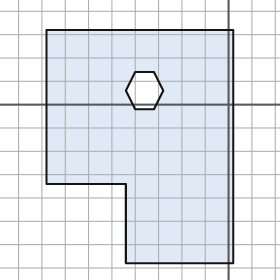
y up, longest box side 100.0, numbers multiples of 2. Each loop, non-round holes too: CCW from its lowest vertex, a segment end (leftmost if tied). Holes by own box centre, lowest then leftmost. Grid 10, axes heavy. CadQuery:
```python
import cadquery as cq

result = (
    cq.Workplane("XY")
    .moveTo(-44.0, -68.0)
    .lineTo(2.0, -68.0)
    .lineTo(2.0, 32.0)
    .lineTo(-78.0, 32.0)
    .lineTo(-78.0, -34.0)
    .lineTo(-44.0, -34.0)
    .close()
    .moveTo(-40.0, -2.0)
    .lineTo(-32.0, -2.0)
    .lineTo(-28.0, 6.0)
    .lineTo(-32.0, 14.0)
    .lineTo(-40.0, 14.0)
    .lineTo(-44.0, 6.0)
    .close()
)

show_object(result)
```